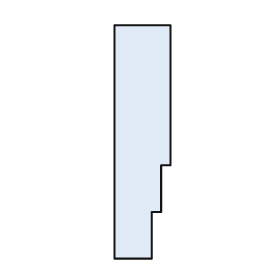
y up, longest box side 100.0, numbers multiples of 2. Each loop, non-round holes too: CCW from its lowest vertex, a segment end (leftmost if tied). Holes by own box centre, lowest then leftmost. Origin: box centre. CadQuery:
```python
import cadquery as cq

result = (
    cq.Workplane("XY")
    .moveTo(-12.0, -50.0)
    .lineTo(4.0, -50.0)
    .lineTo(4.0, -30.0)
    .lineTo(8.0, -30.0)
    .lineTo(8.0, -10.0)
    .lineTo(12.0, -10.0)
    .lineTo(12.0, 50.0)
    .lineTo(-12.0, 50.0)
    .close()
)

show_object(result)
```